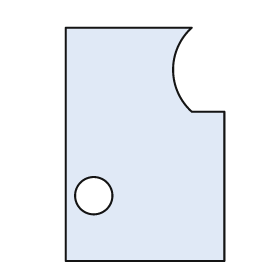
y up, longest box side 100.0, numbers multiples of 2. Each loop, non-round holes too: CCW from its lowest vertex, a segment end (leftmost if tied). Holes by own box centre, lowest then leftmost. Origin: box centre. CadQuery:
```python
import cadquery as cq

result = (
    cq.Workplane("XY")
    .moveTo(-34.0, -50.0)
    .lineTo(34.0, -50.0)
    .lineTo(34.0, 14.0)
    .lineTo(20.0, 14.0)
    .threePointArc((12.0, 32.0), (20.0, 50.0))
    .lineTo(-34.0, 50.0)
    .close()
    .moveTo(-22.0, -22.0)
    .circle(8.0)
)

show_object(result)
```